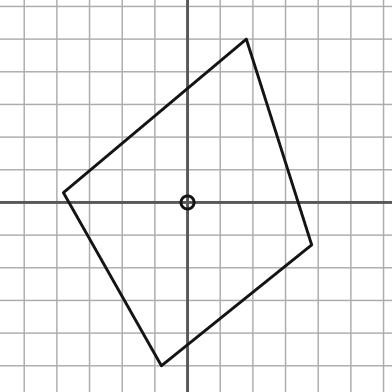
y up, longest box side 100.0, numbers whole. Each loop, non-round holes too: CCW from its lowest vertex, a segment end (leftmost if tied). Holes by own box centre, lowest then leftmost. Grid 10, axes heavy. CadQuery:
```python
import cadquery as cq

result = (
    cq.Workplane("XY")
    .moveTo(-8.0, -50.0)
    .lineTo(38.0, -13.0)
    .lineTo(18.0, 50.0)
    .lineTo(-38.0, 3.0)
    .close()
    .moveTo(0.0, 0.0)
    .circle(2.0)
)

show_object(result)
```